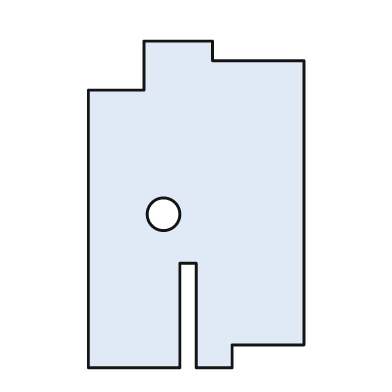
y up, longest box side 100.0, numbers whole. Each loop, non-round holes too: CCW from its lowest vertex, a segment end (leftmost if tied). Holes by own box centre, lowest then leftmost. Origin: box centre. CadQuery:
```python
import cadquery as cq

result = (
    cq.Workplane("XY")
    .moveTo(-33.0, -50.0)
    .lineTo(-5.0, -50.0)
    .lineTo(-5.0, -18.0)
    .lineTo(0.0, -18.0)
    .lineTo(0.0, -50.0)
    .lineTo(11.0, -50.0)
    .lineTo(11.0, -43.0)
    .lineTo(33.0, -43.0)
    .lineTo(33.0, 44.0)
    .lineTo(5.0, 44.0)
    .lineTo(5.0, 50.0)
    .lineTo(-16.0, 50.0)
    .lineTo(-16.0, 35.0)
    .lineTo(-33.0, 35.0)
    .close()
    .moveTo(-10.0, -3.0)
    .circle(5.0)
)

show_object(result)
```